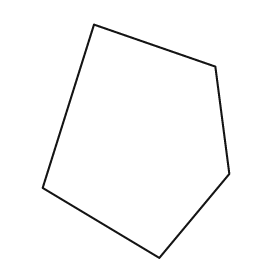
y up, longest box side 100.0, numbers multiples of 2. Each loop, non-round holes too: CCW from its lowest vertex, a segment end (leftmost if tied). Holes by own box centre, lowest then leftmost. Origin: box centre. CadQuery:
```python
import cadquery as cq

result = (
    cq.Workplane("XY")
    .moveTo(10.0, -50.0)
    .lineTo(40.0, -14.0)
    .lineTo(34.0, 32.0)
    .lineTo(-18.0, 50.0)
    .lineTo(-40.0, -20.0)
    .close()
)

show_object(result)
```